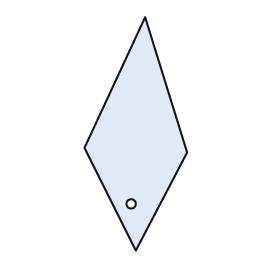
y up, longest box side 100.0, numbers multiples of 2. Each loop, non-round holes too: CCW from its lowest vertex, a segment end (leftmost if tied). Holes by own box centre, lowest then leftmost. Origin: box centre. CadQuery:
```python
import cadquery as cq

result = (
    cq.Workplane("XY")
    .moveTo(0.0, -50.0)
    .lineTo(22.0, -8.0)
    .lineTo(4.0, 50.0)
    .lineTo(-22.0, -6.0)
    .close()
    .moveTo(-2.0, -30.0)
    .circle(2.0)
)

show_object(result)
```